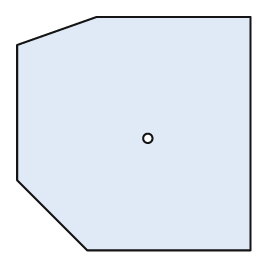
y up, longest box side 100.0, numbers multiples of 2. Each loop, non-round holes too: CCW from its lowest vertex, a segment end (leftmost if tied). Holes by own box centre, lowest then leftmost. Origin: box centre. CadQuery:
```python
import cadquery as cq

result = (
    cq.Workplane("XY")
    .moveTo(-20.0, -50.0)
    .lineTo(50.0, -50.0)
    .lineTo(50.0, 50.0)
    .lineTo(-16.0, 50.0)
    .lineTo(-50.0, 38.0)
    .lineTo(-50.0, -20.0)
    .close()
    .moveTo(6.0, -2.0)
    .circle(2.0)
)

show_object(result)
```